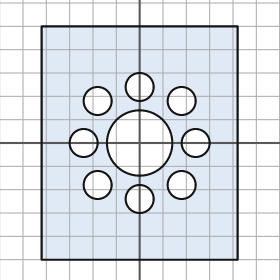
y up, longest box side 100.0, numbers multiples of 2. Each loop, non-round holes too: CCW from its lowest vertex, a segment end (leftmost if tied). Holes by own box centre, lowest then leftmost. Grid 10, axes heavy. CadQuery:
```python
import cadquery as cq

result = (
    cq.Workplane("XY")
    .moveTo(-42.0, -50.0)
    .lineTo(42.0, -50.0)
    .lineTo(42.0, 50.0)
    .lineTo(-42.0, 50.0)
    .close()
    .moveTo(0.0, -24.0)
    .circle(6.0)
    .moveTo(-18.0, -18.0)
    .circle(6.0)
    .moveTo(18.0, -18.0)
    .circle(6.0)
    .moveTo(-24.0, 0.0)
    .circle(6.0)
    .moveTo(0.0, 0.0)
    .circle(14.0)
    .moveTo(24.0, 0.0)
    .circle(6.0)
    .moveTo(-18.0, 18.0)
    .circle(6.0)
    .moveTo(18.0, 18.0)
    .circle(6.0)
    .moveTo(0.0, 24.0)
    .circle(6.0)
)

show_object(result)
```